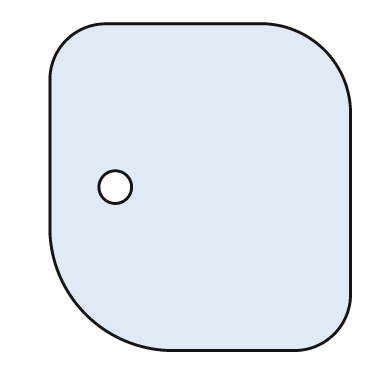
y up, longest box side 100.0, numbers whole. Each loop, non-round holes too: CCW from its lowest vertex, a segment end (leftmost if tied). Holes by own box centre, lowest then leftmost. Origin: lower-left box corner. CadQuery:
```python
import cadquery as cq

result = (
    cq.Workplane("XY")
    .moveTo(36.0, 0.0)
    .lineTo(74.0, 0.0)
    .threePointArc((87.0, 5.0), (92.0, 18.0))
    .lineTo(92.0, 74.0)
    .threePointArc((84.0, 92.0), (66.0, 100.0))
    .lineTo(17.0, 100.0)
    .threePointArc((5.0, 95.0), (0.0, 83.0))
    .lineTo(0.0, 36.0)
    .threePointArc((11.0, 11.0), (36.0, 0.0))
    .close()
    .moveTo(20.0, 50.0)
    .circle(5.0)
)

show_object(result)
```